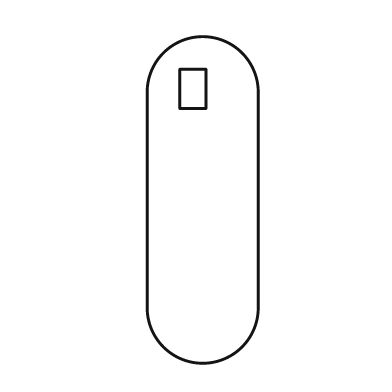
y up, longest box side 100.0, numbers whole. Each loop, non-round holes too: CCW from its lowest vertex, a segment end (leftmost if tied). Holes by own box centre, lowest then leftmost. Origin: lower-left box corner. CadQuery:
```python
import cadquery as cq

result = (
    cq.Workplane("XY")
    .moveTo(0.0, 17.0)
    .threePointArc((17.0, 0.0), (34.0, 17.0))
    .lineTo(34.0, 83.0)
    .threePointArc((17.0, 100.0), (0.0, 83.0))
    .close()
    .moveTo(10.0, 78.0)
    .lineTo(18.0, 78.0)
    .lineTo(18.0, 90.0)
    .lineTo(10.0, 90.0)
    .close()
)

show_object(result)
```